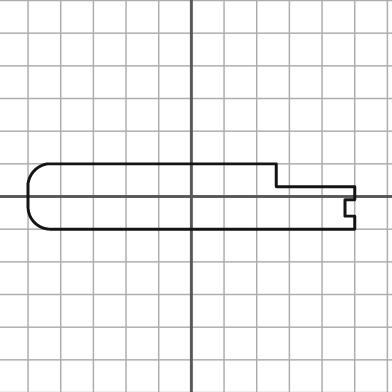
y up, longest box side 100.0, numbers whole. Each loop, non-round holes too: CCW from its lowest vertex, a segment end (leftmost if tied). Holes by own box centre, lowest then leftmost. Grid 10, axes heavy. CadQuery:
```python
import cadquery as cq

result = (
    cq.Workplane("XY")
    .moveTo(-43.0, -10.0)
    .lineTo(50.0, -10.0)
    .lineTo(50.0, -6.0)
    .lineTo(47.0, -6.0)
    .lineTo(47.0, -1.0)
    .lineTo(50.0, -1.0)
    .lineTo(50.0, 3.0)
    .lineTo(26.0, 3.0)
    .lineTo(26.0, 10.0)
    .lineTo(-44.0, 10.0)
    .threePointArc((-48.0, 8.0), (-50.0, 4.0))
    .lineTo(-50.0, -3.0)
    .threePointArc((-48.0, -8.0), (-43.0, -10.0))
    .close()
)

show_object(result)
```